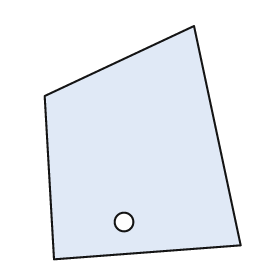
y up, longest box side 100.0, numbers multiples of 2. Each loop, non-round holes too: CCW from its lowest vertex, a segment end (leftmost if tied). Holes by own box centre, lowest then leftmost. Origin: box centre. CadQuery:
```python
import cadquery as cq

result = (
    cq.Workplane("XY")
    .moveTo(-38.0, -50.0)
    .lineTo(42.0, -44.0)
    .lineTo(22.0, 50.0)
    .lineTo(-42.0, 20.0)
    .close()
    .moveTo(-8.0, -34.0)
    .circle(4.0)
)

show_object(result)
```